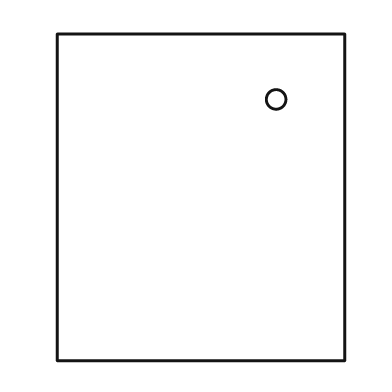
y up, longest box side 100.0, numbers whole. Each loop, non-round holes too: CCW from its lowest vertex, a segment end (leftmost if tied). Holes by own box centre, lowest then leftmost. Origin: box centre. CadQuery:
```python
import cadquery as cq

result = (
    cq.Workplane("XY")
    .moveTo(-44.0, -50.0)
    .lineTo(44.0, -50.0)
    .lineTo(44.0, 50.0)
    .lineTo(-44.0, 50.0)
    .close()
    .moveTo(23.0, 30.0)
    .circle(3.0)
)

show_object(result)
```